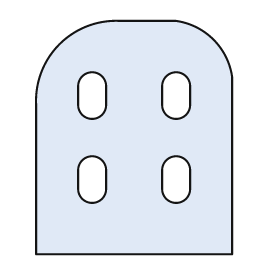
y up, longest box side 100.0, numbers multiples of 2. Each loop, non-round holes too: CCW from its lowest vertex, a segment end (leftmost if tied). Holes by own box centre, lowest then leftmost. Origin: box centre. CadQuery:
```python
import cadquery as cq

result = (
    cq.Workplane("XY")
    .moveTo(-42.0, -50.0)
    .lineTo(42.0, -50.0)
    .lineTo(42.0, 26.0)
    .threePointArc((34.0, 42.0), (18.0, 50.0))
    .lineTo(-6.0, 50.0)
    .threePointArc((-32.0, 40.0), (-42.0, 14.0))
    .close()
    .moveTo(-24.0, -22.0)
    .threePointArc((-18.0, -28.0), (-12.0, -22.0))
    .lineTo(-12.0, -14.0)
    .threePointArc((-18.0, -8.0), (-24.0, -14.0))
    .close()
    .moveTo(12.0, -22.0)
    .threePointArc((18.0, -28.0), (24.0, -22.0))
    .lineTo(24.0, -14.0)
    .threePointArc((18.0, -8.0), (12.0, -14.0))
    .close()
    .moveTo(-24.0, 14.0)
    .threePointArc((-18.0, 8.0), (-12.0, 14.0))
    .lineTo(-12.0, 22.0)
    .threePointArc((-18.0, 28.0), (-24.0, 22.0))
    .close()
    .moveTo(12.0, 14.0)
    .threePointArc((18.0, 8.0), (24.0, 14.0))
    .lineTo(24.0, 22.0)
    .threePointArc((18.0, 28.0), (12.0, 22.0))
    .close()
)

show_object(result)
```